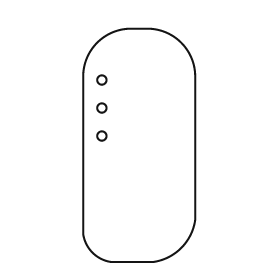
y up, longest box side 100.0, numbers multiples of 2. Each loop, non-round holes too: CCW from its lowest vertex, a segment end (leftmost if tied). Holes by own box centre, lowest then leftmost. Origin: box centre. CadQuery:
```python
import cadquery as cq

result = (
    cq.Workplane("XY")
    .moveTo(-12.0, -50.0)
    .lineTo(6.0, -50.0)
    .threePointArc((18.0, -44.0), (24.0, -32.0))
    .lineTo(24.0, 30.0)
    .threePointArc((18.0, 44.0), (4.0, 50.0))
    .lineTo(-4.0, 50.0)
    .threePointArc((-18.0, 44.0), (-24.0, 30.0))
    .lineTo(-24.0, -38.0)
    .threePointArc((-20.0, -46.0), (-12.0, -50.0))
    .close()
    .moveTo(-16.0, 4.0)
    .circle(2.0)
    .moveTo(-16.0, 16.0)
    .circle(2.0)
    .moveTo(-16.0, 28.0)
    .circle(2.0)
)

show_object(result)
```